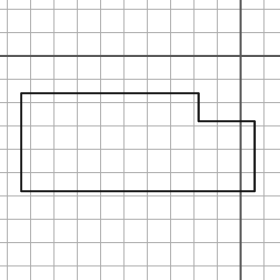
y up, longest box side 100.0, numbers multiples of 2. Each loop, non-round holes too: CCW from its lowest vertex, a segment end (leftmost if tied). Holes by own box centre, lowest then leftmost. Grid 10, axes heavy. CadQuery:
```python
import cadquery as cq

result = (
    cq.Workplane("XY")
    .moveTo(-94.0, -58.0)
    .lineTo(6.0, -58.0)
    .lineTo(6.0, -28.0)
    .lineTo(-18.0, -28.0)
    .lineTo(-18.0, -16.0)
    .lineTo(-94.0, -16.0)
    .close()
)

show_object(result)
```